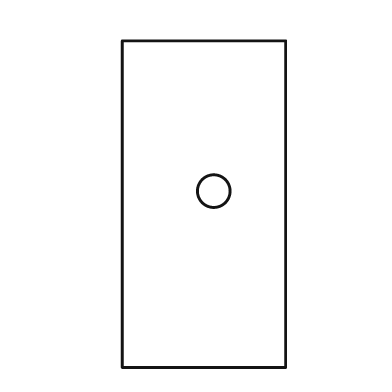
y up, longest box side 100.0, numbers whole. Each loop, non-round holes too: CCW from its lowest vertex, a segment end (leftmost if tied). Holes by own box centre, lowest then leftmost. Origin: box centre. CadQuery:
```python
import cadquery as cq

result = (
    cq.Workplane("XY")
    .moveTo(-25.0, -50.0)
    .lineTo(25.0, -50.0)
    .lineTo(25.0, 50.0)
    .lineTo(-25.0, 50.0)
    .close()
    .moveTo(3.0, 4.0)
    .circle(5.0)
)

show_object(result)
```